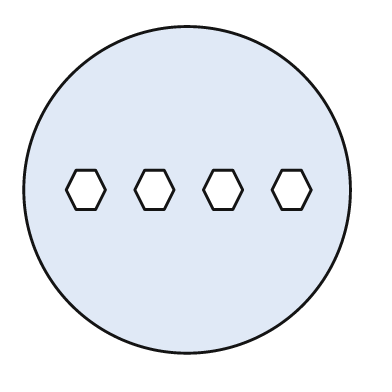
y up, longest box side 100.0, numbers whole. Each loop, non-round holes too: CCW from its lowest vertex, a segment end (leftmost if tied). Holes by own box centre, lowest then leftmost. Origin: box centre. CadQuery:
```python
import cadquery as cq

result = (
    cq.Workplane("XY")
    .moveTo(0.0, 0.0)
    .circle(50.0)
    .moveTo(-34.0, -6.0)
    .lineTo(-28.0, -6.0)
    .lineTo(-25.0, 0.0)
    .lineTo(-28.0, 6.0)
    .lineTo(-34.0, 6.0)
    .lineTo(-37.0, 0.0)
    .close()
    .moveTo(-13.0, -6.0)
    .lineTo(-7.0, -6.0)
    .lineTo(-4.0, 0.0)
    .lineTo(-7.0, 6.0)
    .lineTo(-13.0, 6.0)
    .lineTo(-16.0, 0.0)
    .close()
    .moveTo(8.0, -6.0)
    .lineTo(14.0, -6.0)
    .lineTo(17.0, 0.0)
    .lineTo(14.0, 6.0)
    .lineTo(8.0, 6.0)
    .lineTo(5.0, 0.0)
    .close()
    .moveTo(29.0, -6.0)
    .lineTo(35.0, -6.0)
    .lineTo(38.0, 0.0)
    .lineTo(35.0, 6.0)
    .lineTo(29.0, 6.0)
    .lineTo(26.0, 0.0)
    .close()
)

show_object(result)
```